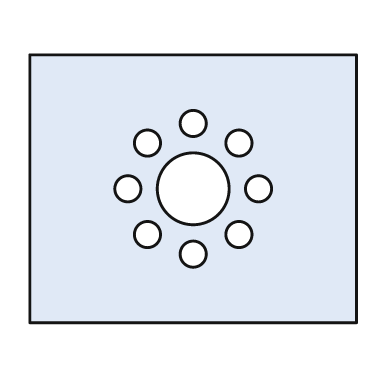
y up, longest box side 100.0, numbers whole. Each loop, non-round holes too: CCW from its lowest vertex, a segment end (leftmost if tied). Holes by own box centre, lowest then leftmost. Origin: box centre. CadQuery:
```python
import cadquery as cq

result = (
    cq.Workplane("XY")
    .moveTo(-50.0, -41.0)
    .lineTo(50.0, -41.0)
    .lineTo(50.0, 41.0)
    .lineTo(-50.0, 41.0)
    .close()
    .moveTo(0.0, -20.0)
    .circle(4.0)
    .moveTo(-14.0, -14.0)
    .circle(4.0)
    .moveTo(14.0, -14.0)
    .circle(4.0)
    .moveTo(-20.0, 0.0)
    .circle(4.0)
    .moveTo(0.0, 0.0)
    .circle(11.0)
    .moveTo(20.0, 0.0)
    .circle(4.0)
    .moveTo(-14.0, 14.0)
    .circle(4.0)
    .moveTo(14.0, 14.0)
    .circle(4.0)
    .moveTo(0.0, 20.0)
    .circle(4.0)
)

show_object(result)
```